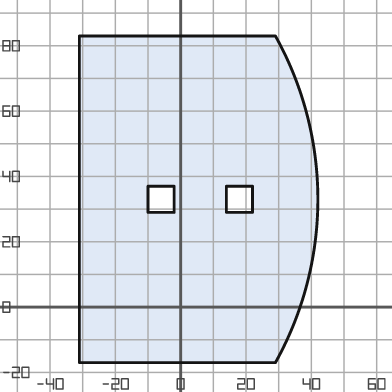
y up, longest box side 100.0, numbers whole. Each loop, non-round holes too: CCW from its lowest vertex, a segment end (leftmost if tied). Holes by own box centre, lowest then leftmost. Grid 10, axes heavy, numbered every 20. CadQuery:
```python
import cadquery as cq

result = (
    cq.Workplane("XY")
    .moveTo(-31.0, -17.0)
    .lineTo(29.0, -17.0)
    .threePointArc((42.0, 33.0), (29.0, 83.0))
    .lineTo(-31.0, 83.0)
    .close()
    .moveTo(-10.0, 29.0)
    .lineTo(-2.0, 29.0)
    .lineTo(-2.0, 37.0)
    .lineTo(-10.0, 37.0)
    .close()
    .moveTo(14.0, 29.0)
    .lineTo(22.0, 29.0)
    .lineTo(22.0, 37.0)
    .lineTo(14.0, 37.0)
    .close()
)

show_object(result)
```